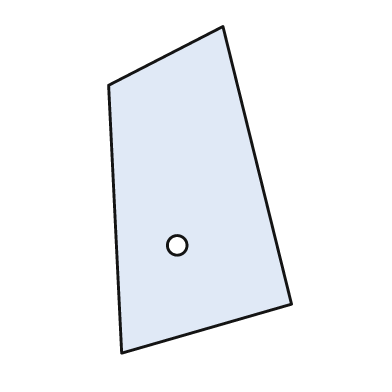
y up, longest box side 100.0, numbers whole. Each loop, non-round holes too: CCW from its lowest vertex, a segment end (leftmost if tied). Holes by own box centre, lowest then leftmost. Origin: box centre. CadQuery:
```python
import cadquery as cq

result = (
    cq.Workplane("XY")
    .moveTo(-24.0, -50.0)
    .lineTo(28.0, -35.0)
    .lineTo(7.0, 50.0)
    .lineTo(-28.0, 32.0)
    .close()
    .moveTo(-7.0, -17.0)
    .circle(3.0)
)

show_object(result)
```